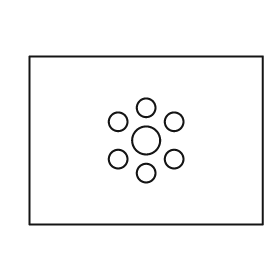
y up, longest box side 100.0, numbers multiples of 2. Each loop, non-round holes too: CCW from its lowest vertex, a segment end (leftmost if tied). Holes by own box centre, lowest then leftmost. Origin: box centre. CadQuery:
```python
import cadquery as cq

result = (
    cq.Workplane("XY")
    .moveTo(-50.0, -36.0)
    .lineTo(50.0, -36.0)
    .lineTo(50.0, 36.0)
    .lineTo(-50.0, 36.0)
    .close()
    .moveTo(0.0, -14.0)
    .circle(4.0)
    .moveTo(-12.0, -8.0)
    .circle(4.0)
    .moveTo(12.0, -8.0)
    .circle(4.0)
    .moveTo(0.0, 0.0)
    .circle(6.0)
    .moveTo(-12.0, 8.0)
    .circle(4.0)
    .moveTo(12.0, 8.0)
    .circle(4.0)
    .moveTo(0.0, 14.0)
    .circle(4.0)
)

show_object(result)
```